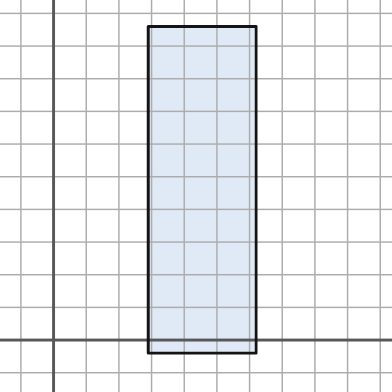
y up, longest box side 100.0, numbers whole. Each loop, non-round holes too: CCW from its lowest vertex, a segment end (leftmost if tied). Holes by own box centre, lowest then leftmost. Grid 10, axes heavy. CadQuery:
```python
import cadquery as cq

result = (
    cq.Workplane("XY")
    .moveTo(29.0, -4.0)
    .lineTo(62.0, -4.0)
    .lineTo(62.0, 96.0)
    .lineTo(29.0, 96.0)
    .close()
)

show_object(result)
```